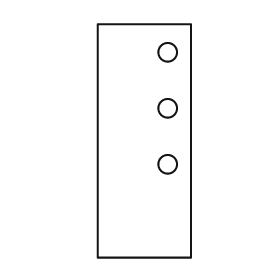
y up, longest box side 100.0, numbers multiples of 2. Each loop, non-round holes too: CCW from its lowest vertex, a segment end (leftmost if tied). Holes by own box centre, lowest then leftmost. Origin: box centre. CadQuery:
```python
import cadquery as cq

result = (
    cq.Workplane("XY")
    .moveTo(-20.0, -50.0)
    .lineTo(20.0, -50.0)
    .lineTo(20.0, 50.0)
    .lineTo(-20.0, 50.0)
    .close()
    .moveTo(10.0, -10.0)
    .circle(4.0)
    .moveTo(10.0, 14.0)
    .circle(4.0)
    .moveTo(10.0, 38.0)
    .circle(4.0)
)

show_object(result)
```